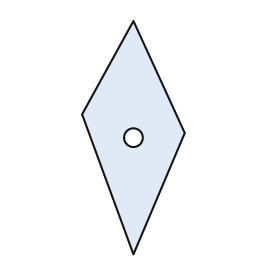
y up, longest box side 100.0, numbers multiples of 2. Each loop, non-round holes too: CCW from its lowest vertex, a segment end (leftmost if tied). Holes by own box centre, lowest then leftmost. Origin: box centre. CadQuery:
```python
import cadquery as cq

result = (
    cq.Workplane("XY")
    .moveTo(0.0, -50.0)
    .lineTo(22.0, 2.0)
    .lineTo(0.0, 50.0)
    .lineTo(-22.0, 10.0)
    .close()
    .moveTo(0.0, 0.0)
    .circle(4.0)
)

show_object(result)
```